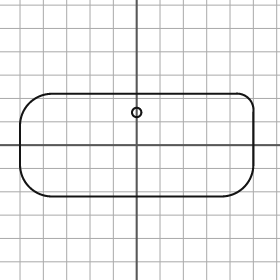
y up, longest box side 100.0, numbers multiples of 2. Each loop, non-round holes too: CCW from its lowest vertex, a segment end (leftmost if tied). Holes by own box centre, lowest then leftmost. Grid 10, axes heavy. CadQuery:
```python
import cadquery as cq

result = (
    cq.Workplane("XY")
    .moveTo(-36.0, -22.0)
    .lineTo(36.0, -22.0)
    .threePointArc((46.0, -18.0), (50.0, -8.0))
    .lineTo(50.0, 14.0)
    .threePointArc((48.0, 20.0), (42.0, 22.0))
    .lineTo(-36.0, 22.0)
    .threePointArc((-46.0, 18.0), (-50.0, 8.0))
    .lineTo(-50.0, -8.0)
    .threePointArc((-46.0, -18.0), (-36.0, -22.0))
    .close()
    .moveTo(0.0, 14.0)
    .circle(2.0)
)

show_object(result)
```